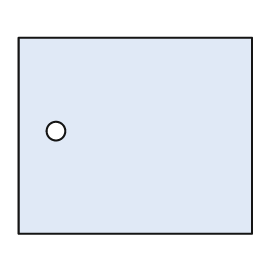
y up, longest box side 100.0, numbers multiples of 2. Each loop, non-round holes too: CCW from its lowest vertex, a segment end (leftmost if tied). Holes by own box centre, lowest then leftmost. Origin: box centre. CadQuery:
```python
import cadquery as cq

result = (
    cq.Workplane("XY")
    .moveTo(-50.0, -42.0)
    .lineTo(50.0, -42.0)
    .lineTo(50.0, 42.0)
    .lineTo(-50.0, 42.0)
    .close()
    .moveTo(-34.0, 2.0)
    .circle(4.0)
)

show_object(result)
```